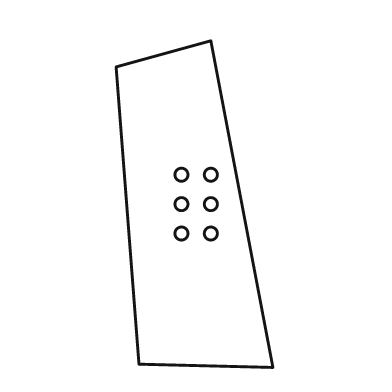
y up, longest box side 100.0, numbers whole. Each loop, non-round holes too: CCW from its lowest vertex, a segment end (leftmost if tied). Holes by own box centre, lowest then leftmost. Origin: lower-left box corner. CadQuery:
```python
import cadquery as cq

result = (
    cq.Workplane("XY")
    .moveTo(48.0, 0.0)
    .lineTo(29.0, 100.0)
    .lineTo(0.0, 92.0)
    .lineTo(7.0, 1.0)
    .close()
    .moveTo(20.0, 41.0)
    .circle(2.0)
    .moveTo(29.0, 41.0)
    .circle(2.0)
    .moveTo(20.0, 50.0)
    .circle(2.0)
    .moveTo(29.0, 50.0)
    .circle(2.0)
    .moveTo(20.0, 59.0)
    .circle(2.0)
    .moveTo(29.0, 59.0)
    .circle(2.0)
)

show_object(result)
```